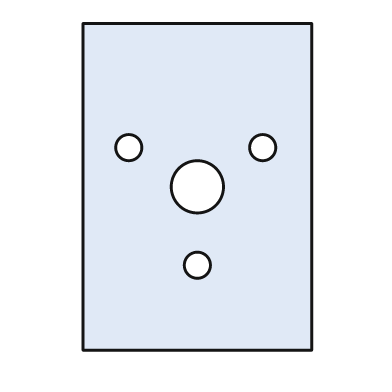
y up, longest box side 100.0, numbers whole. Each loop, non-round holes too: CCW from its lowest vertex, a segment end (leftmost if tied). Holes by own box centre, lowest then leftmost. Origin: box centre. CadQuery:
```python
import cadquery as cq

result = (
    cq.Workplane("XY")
    .moveTo(-35.0, -50.0)
    .lineTo(35.0, -50.0)
    .lineTo(35.0, 50.0)
    .lineTo(-35.0, 50.0)
    .close()
    .moveTo(0.0, -24.0)
    .circle(4.0)
    .moveTo(0.0, 0.0)
    .circle(8.0)
    .moveTo(-21.0, 12.0)
    .circle(4.0)
    .moveTo(20.0, 12.0)
    .circle(4.0)
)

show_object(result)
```